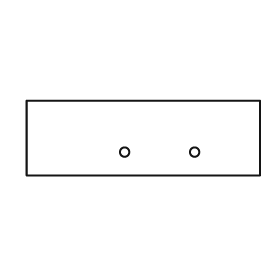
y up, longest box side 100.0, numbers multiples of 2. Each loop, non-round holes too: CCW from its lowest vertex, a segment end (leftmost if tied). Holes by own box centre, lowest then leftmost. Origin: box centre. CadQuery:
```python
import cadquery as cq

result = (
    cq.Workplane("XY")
    .moveTo(-50.0, -16.0)
    .lineTo(50.0, -16.0)
    .lineTo(50.0, 16.0)
    .lineTo(-50.0, 16.0)
    .close()
    .moveTo(-8.0, -6.0)
    .circle(2.0)
    .moveTo(22.0, -6.0)
    .circle(2.0)
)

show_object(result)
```